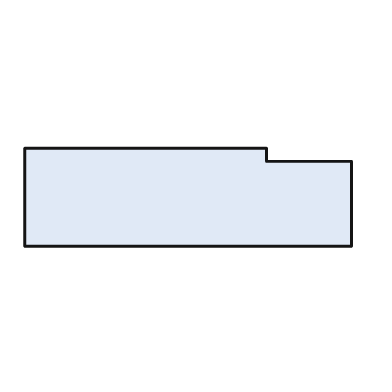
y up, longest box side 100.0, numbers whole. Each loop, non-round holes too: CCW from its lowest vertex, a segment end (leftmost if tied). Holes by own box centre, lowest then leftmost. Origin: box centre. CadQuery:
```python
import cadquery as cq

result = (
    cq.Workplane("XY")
    .moveTo(-50.0, -15.0)
    .lineTo(50.0, -15.0)
    .lineTo(50.0, 11.0)
    .lineTo(24.0, 11.0)
    .lineTo(24.0, 15.0)
    .lineTo(-50.0, 15.0)
    .close()
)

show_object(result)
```